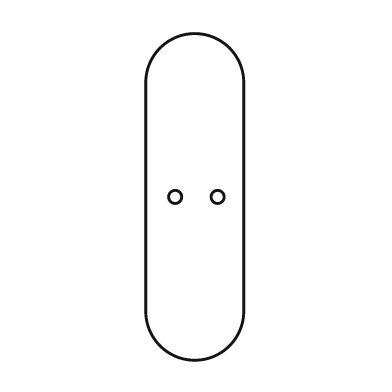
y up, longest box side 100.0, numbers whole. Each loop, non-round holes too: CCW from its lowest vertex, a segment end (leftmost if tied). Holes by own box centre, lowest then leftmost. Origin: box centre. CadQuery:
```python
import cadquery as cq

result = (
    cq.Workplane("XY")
    .moveTo(-15.0, -35.0)
    .threePointArc((0.0, -50.0), (15.0, -35.0))
    .lineTo(15.0, 35.0)
    .threePointArc((0.0, 50.0), (-15.0, 35.0))
    .close()
    .moveTo(-6.0, 0.0)
    .circle(2.0)
    .moveTo(7.0, 0.0)
    .circle(2.0)
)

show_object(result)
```